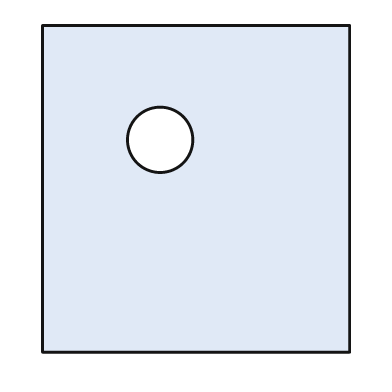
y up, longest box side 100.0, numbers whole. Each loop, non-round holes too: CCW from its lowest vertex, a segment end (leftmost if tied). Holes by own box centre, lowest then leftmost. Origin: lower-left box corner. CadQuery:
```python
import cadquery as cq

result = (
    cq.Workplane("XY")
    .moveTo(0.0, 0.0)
    .lineTo(94.0, 0.0)
    .lineTo(94.0, 100.0)
    .lineTo(0.0, 100.0)
    .close()
    .moveTo(36.0, 65.0)
    .circle(10.0)
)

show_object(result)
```